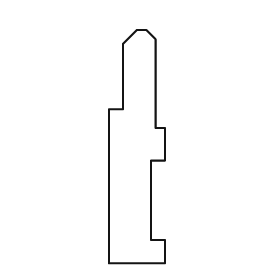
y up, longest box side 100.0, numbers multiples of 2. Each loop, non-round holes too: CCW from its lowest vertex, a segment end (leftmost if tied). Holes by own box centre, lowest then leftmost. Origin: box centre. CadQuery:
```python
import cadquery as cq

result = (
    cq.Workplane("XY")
    .moveTo(-12.0, -50.0)
    .lineTo(12.0, -50.0)
    .lineTo(12.0, -40.0)
    .lineTo(6.0, -40.0)
    .lineTo(6.0, -6.0)
    .lineTo(12.0, -6.0)
    .lineTo(12.0, 8.0)
    .lineTo(8.0, 8.0)
    .lineTo(8.0, 46.0)
    .lineTo(4.0, 50.0)
    .lineTo(0.0, 50.0)
    .lineTo(-6.0, 44.0)
    .lineTo(-6.0, 16.0)
    .lineTo(-12.0, 16.0)
    .close()
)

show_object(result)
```